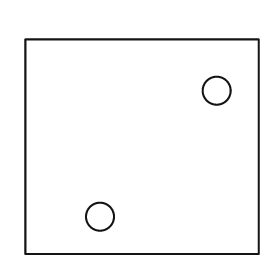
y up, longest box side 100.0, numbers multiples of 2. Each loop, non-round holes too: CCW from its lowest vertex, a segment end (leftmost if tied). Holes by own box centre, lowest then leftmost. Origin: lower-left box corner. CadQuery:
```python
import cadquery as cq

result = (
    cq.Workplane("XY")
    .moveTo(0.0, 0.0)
    .lineTo(100.0, 0.0)
    .lineTo(100.0, 92.0)
    .lineTo(0.0, 92.0)
    .close()
    .moveTo(32.0, 16.0)
    .circle(6.0)
    .moveTo(82.0, 70.0)
    .circle(6.0)
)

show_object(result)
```